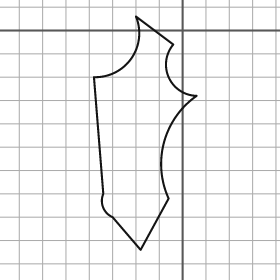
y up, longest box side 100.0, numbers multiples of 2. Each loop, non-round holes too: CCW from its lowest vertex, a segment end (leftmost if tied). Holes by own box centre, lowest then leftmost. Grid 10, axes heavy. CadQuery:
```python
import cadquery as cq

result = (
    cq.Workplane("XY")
    .moveTo(-18.0, -94.0)
    .lineTo(-6.0, -72.0)
    .threePointArc((-8.0, -48.0), (6.0, -28.0))
    .threePointArc((-6.0, -20.0), (-4.0, -6.0))
    .lineTo(-20.0, 6.0)
    .threePointArc((-22.0, -12.0), (-38.0, -20.0))
    .lineTo(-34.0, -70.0)
    .threePointArc((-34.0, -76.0), (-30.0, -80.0))
    .close()
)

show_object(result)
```